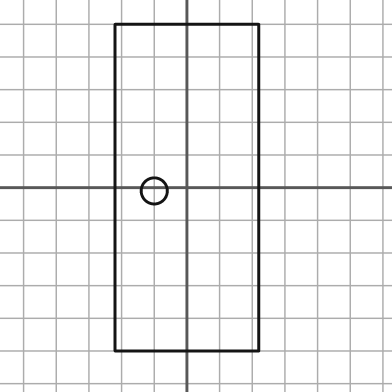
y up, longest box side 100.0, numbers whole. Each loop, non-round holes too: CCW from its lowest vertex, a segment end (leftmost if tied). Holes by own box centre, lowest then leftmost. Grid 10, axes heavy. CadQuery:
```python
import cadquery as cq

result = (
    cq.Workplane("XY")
    .moveTo(-22.0, -50.0)
    .lineTo(22.0, -50.0)
    .lineTo(22.0, 50.0)
    .lineTo(-22.0, 50.0)
    .close()
    .moveTo(-10.0, -1.0)
    .circle(4.0)
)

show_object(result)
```